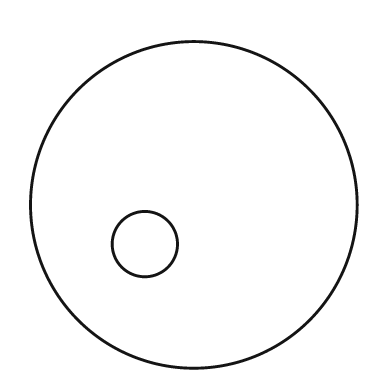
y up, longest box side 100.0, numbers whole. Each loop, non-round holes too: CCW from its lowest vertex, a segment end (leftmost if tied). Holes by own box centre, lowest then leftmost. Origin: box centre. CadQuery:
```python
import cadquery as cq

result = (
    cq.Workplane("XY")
    .moveTo(0.0, 0.0)
    .circle(50.0)
    .moveTo(-15.0, -12.0)
    .circle(10.0)
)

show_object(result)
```